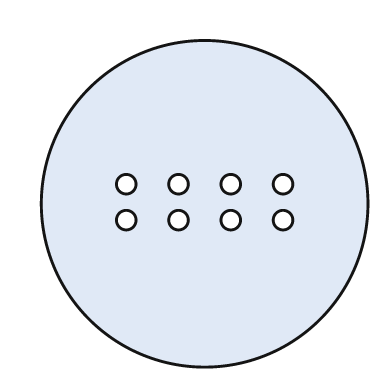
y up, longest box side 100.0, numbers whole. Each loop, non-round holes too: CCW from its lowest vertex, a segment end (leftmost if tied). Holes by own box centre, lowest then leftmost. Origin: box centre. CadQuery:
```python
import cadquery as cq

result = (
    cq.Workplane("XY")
    .moveTo(0.0, 0.0)
    .circle(50.0)
    .moveTo(-24.0, -5.0)
    .circle(3.0)
    .moveTo(-8.0, -5.0)
    .circle(3.0)
    .moveTo(8.0, -5.0)
    .circle(3.0)
    .moveTo(24.0, -5.0)
    .circle(3.0)
    .moveTo(-24.0, 6.0)
    .circle(3.0)
    .moveTo(-8.0, 6.0)
    .circle(3.0)
    .moveTo(8.0, 6.0)
    .circle(3.0)
    .moveTo(24.0, 6.0)
    .circle(3.0)
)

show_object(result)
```